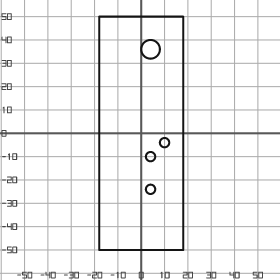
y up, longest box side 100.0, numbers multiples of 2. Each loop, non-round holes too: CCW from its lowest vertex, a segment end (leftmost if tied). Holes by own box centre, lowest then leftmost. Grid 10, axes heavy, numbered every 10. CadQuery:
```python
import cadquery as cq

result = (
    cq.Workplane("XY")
    .moveTo(-18.0, -50.0)
    .lineTo(18.0, -50.0)
    .lineTo(18.0, 50.0)
    .lineTo(-18.0, 50.0)
    .close()
    .moveTo(4.0, -24.0)
    .circle(2.0)
    .moveTo(4.0, -10.0)
    .circle(2.0)
    .moveTo(10.0, -4.0)
    .circle(2.0)
    .moveTo(4.0, 36.0)
    .circle(4.0)
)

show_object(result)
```